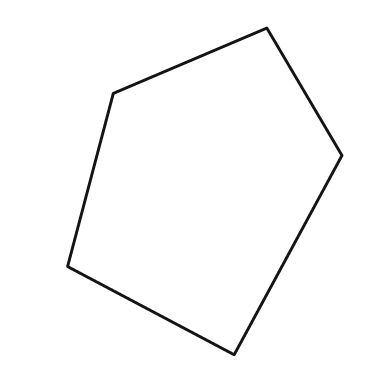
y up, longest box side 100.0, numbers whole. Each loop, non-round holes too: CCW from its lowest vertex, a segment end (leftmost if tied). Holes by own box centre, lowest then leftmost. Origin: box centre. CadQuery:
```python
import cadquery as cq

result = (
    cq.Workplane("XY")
    .moveTo(9.0, -50.0)
    .lineTo(42.0, 11.0)
    .lineTo(19.0, 50.0)
    .lineTo(-28.0, 30.0)
    .lineTo(-42.0, -23.0)
    .close()
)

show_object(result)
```